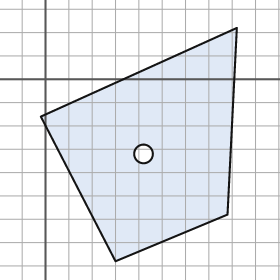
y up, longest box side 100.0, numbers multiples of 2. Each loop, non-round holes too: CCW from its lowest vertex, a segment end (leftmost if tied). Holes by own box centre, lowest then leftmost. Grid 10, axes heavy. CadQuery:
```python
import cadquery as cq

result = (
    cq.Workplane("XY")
    .moveTo(30.0, -78.0)
    .lineTo(78.0, -58.0)
    .lineTo(82.0, 22.0)
    .lineTo(-2.0, -16.0)
    .close()
    .moveTo(42.0, -32.0)
    .circle(4.0)
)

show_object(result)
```